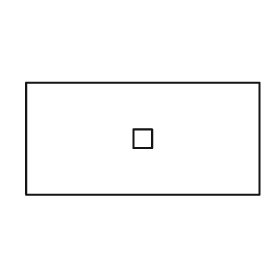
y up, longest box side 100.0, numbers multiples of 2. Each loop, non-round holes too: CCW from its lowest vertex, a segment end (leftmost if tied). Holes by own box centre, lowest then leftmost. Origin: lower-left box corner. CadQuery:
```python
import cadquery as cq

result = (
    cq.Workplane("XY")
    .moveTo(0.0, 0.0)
    .lineTo(100.0, 0.0)
    .lineTo(100.0, 48.0)
    .lineTo(0.0, 48.0)
    .close()
    .moveTo(46.0, 20.0)
    .lineTo(54.0, 20.0)
    .lineTo(54.0, 28.0)
    .lineTo(46.0, 28.0)
    .close()
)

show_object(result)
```